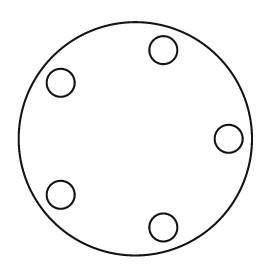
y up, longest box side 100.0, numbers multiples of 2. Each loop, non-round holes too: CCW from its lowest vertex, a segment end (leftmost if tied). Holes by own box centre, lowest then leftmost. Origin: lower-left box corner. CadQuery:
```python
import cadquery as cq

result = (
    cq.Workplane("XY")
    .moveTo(50.0, 50.0)
    .circle(50.0)
    .moveTo(62.0, 12.0)
    .circle(6.0)
    .moveTo(18.0, 26.0)
    .circle(6.0)
    .moveTo(90.0, 50.0)
    .circle(6.0)
    .moveTo(18.0, 74.0)
    .circle(6.0)
    .moveTo(62.0, 88.0)
    .circle(6.0)
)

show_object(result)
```